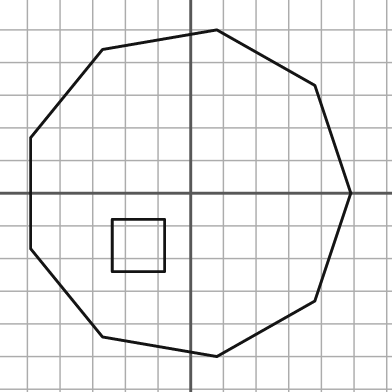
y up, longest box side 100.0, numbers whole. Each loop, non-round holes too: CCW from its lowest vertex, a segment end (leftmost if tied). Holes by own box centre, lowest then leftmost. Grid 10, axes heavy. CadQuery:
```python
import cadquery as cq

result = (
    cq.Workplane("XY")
    .moveTo(8.0, -50.0)
    .lineTo(38.0, -33.0)
    .lineTo(49.0, 0.0)
    .lineTo(38.0, 33.0)
    .lineTo(8.0, 50.0)
    .lineTo(-27.0, 44.0)
    .lineTo(-49.0, 17.0)
    .lineTo(-49.0, -17.0)
    .lineTo(-27.0, -44.0)
    .close()
    .moveTo(-24.0, -24.0)
    .lineTo(-8.0, -24.0)
    .lineTo(-8.0, -8.0)
    .lineTo(-24.0, -8.0)
    .close()
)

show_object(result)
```